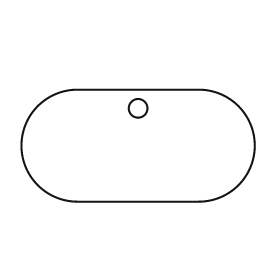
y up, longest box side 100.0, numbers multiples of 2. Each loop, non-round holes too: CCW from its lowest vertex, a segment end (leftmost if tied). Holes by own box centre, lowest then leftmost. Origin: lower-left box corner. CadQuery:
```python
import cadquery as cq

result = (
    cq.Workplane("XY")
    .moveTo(24.0, 0.0)
    .lineTo(76.0, 0.0)
    .threePointArc((100.0, 24.0), (76.0, 48.0))
    .lineTo(24.0, 48.0)
    .threePointArc((0.0, 24.0), (24.0, 0.0))
    .close()
    .moveTo(50.0, 40.0)
    .circle(4.0)
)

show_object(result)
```